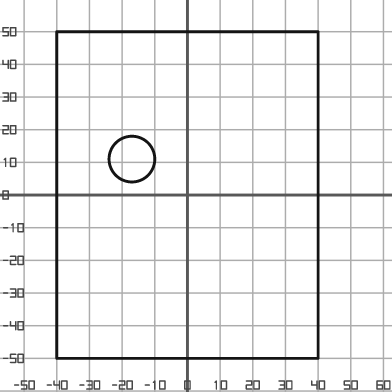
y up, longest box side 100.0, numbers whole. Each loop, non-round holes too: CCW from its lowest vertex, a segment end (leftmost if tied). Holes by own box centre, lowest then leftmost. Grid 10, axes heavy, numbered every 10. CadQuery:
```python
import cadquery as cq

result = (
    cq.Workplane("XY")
    .moveTo(-40.0, -50.0)
    .lineTo(40.0, -50.0)
    .lineTo(40.0, 50.0)
    .lineTo(-40.0, 50.0)
    .close()
    .moveTo(-17.0, 11.0)
    .circle(7.0)
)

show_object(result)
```